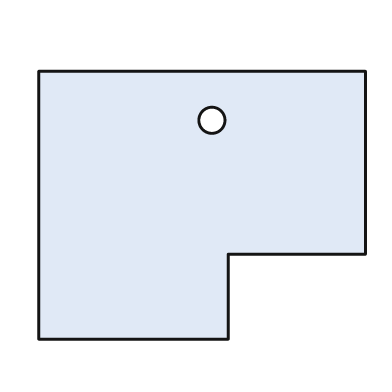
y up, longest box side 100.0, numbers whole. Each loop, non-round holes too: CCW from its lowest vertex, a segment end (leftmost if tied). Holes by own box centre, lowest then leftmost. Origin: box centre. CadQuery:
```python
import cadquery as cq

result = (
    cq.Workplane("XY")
    .moveTo(-50.0, -41.0)
    .lineTo(8.0, -41.0)
    .lineTo(8.0, -15.0)
    .lineTo(50.0, -15.0)
    .lineTo(50.0, 41.0)
    .lineTo(-50.0, 41.0)
    .close()
    .moveTo(3.0, 26.0)
    .circle(4.0)
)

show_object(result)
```